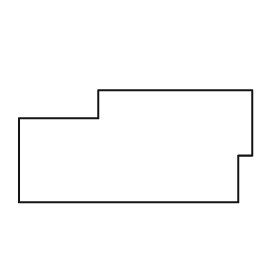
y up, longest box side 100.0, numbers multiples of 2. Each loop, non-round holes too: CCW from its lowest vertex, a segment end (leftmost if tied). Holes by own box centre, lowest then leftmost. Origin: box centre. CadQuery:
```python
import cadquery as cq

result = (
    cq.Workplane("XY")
    .moveTo(-50.0, -24.0)
    .lineTo(44.0, -24.0)
    .lineTo(44.0, -4.0)
    .lineTo(50.0, -4.0)
    .lineTo(50.0, 24.0)
    .lineTo(-16.0, 24.0)
    .lineTo(-16.0, 12.0)
    .lineTo(-50.0, 12.0)
    .close()
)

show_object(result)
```